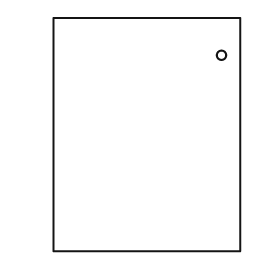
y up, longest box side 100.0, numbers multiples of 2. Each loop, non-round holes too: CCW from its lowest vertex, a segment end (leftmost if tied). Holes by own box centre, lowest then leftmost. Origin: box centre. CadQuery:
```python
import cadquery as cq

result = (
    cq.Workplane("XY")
    .moveTo(-40.0, -50.0)
    .lineTo(40.0, -50.0)
    .lineTo(40.0, 50.0)
    .lineTo(-40.0, 50.0)
    .close()
    .moveTo(32.0, 34.0)
    .circle(2.0)
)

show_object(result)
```